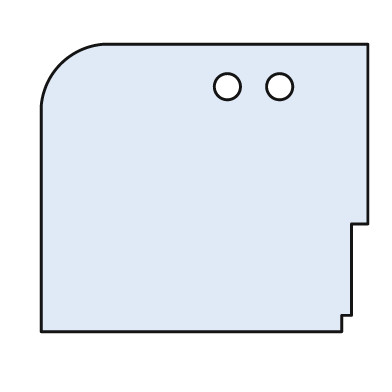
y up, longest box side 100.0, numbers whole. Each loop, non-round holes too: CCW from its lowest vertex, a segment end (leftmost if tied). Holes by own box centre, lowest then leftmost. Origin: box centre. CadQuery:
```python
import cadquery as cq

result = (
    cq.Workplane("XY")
    .moveTo(-50.0, -44.0)
    .lineTo(42.0, -44.0)
    .lineTo(42.0, -39.0)
    .lineTo(45.0, -39.0)
    .lineTo(45.0, -11.0)
    .lineTo(50.0, -11.0)
    .lineTo(50.0, 44.0)
    .lineTo(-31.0, 44.0)
    .threePointArc((-44.0, 38.0), (-50.0, 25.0))
    .close()
    .moveTo(7.0, 31.0)
    .circle(4.0)
    .moveTo(23.0, 31.0)
    .circle(4.0)
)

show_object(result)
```